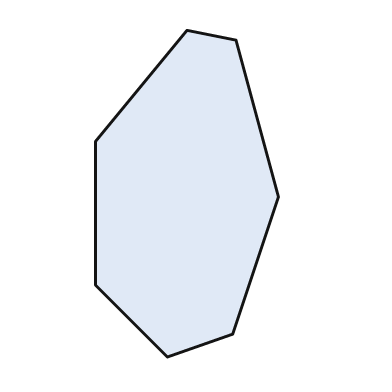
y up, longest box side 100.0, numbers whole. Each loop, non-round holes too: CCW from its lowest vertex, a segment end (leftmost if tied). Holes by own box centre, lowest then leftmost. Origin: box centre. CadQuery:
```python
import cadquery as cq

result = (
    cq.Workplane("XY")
    .moveTo(-6.0, -50.0)
    .lineTo(14.0, -43.0)
    .lineTo(28.0, -1.0)
    .lineTo(15.0, 47.0)
    .lineTo(0.0, 50.0)
    .lineTo(-28.0, 16.0)
    .lineTo(-28.0, -28.0)
    .close()
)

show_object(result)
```